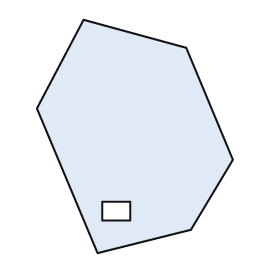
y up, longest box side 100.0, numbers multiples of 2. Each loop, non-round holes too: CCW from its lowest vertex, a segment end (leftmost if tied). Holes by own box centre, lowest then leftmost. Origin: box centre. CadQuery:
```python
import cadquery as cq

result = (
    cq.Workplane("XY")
    .moveTo(-16.0, -50.0)
    .lineTo(24.0, -40.0)
    .lineTo(42.0, -10.0)
    .lineTo(22.0, 38.0)
    .lineTo(-22.0, 50.0)
    .lineTo(-42.0, 12.0)
    .close()
    .moveTo(-14.0, -36.0)
    .lineTo(-2.0, -36.0)
    .lineTo(-2.0, -28.0)
    .lineTo(-14.0, -28.0)
    .close()
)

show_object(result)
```